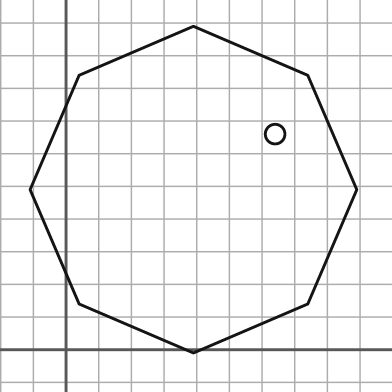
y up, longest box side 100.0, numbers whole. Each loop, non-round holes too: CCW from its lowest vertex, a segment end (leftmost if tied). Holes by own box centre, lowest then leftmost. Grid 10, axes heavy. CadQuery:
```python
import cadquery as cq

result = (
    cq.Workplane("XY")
    .moveTo(39.0, -1.0)
    .lineTo(74.0, 14.0)
    .lineTo(89.0, 49.0)
    .lineTo(74.0, 84.0)
    .lineTo(39.0, 99.0)
    .lineTo(4.0, 84.0)
    .lineTo(-11.0, 49.0)
    .lineTo(4.0, 14.0)
    .close()
    .moveTo(64.0, 66.0)
    .circle(3.0)
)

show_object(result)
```